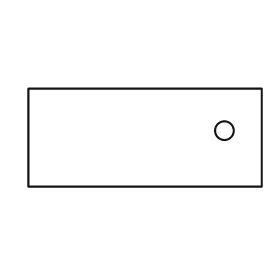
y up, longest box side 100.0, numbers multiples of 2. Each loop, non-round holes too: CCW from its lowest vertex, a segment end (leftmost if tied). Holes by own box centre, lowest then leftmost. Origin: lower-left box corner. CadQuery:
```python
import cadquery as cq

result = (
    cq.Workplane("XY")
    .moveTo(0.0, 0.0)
    .lineTo(100.0, 0.0)
    .lineTo(100.0, 42.0)
    .lineTo(0.0, 42.0)
    .close()
    .moveTo(84.0, 24.0)
    .circle(4.0)
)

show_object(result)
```